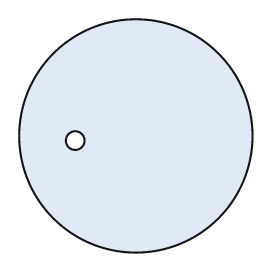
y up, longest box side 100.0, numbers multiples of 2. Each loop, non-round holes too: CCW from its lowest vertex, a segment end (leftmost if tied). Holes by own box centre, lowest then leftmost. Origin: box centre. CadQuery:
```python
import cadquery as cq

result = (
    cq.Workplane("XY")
    .moveTo(0.0, 0.0)
    .circle(50.0)
    .moveTo(-26.0, -2.0)
    .circle(4.0)
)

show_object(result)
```